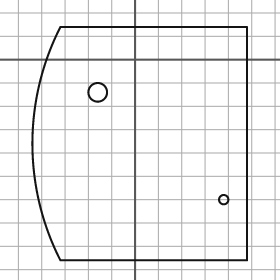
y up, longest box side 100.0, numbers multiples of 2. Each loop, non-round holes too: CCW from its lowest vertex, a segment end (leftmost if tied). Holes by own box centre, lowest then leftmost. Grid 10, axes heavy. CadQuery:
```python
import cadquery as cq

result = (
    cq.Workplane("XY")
    .moveTo(-32.0, -86.0)
    .lineTo(48.0, -86.0)
    .lineTo(48.0, 14.0)
    .lineTo(-32.0, 14.0)
    .threePointArc((-44.0, -36.0), (-32.0, -86.0))
    .close()
    .moveTo(38.0, -60.0)
    .circle(2.0)
    .moveTo(-16.0, -14.0)
    .circle(4.0)
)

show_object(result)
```